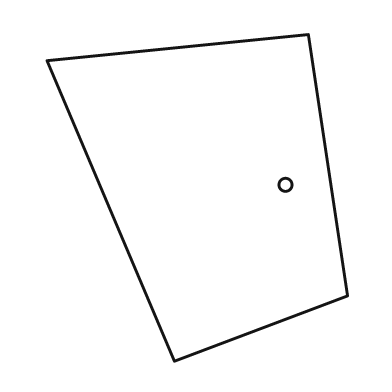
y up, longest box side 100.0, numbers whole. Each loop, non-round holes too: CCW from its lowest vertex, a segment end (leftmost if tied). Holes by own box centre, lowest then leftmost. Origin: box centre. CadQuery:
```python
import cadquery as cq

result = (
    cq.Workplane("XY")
    .moveTo(-7.0, -50.0)
    .lineTo(46.0, -30.0)
    .lineTo(34.0, 50.0)
    .lineTo(-46.0, 42.0)
    .close()
    .moveTo(27.0, 4.0)
    .circle(2.0)
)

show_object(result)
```